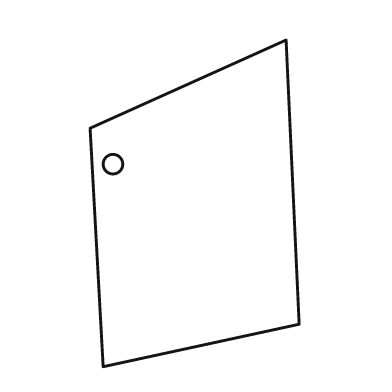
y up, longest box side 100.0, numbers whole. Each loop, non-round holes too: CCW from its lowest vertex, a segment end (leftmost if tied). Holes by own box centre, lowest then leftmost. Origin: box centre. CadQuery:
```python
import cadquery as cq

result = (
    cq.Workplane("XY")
    .moveTo(-28.0, -50.0)
    .lineTo(32.0, -37.0)
    .lineTo(28.0, 50.0)
    .lineTo(-32.0, 23.0)
    .close()
    .moveTo(-25.0, 12.0)
    .circle(3.0)
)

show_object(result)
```